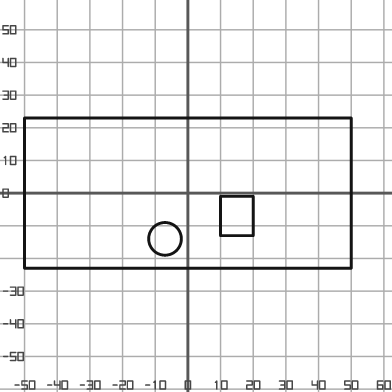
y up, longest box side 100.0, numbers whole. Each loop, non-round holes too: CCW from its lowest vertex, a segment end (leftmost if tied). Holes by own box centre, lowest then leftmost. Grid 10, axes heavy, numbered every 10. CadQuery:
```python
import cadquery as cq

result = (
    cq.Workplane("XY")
    .moveTo(-50.0, -23.0)
    .lineTo(50.0, -23.0)
    .lineTo(50.0, 23.0)
    .lineTo(-50.0, 23.0)
    .close()
    .moveTo(-7.0, -14.0)
    .circle(5.0)
    .moveTo(10.0, -13.0)
    .lineTo(20.0, -13.0)
    .lineTo(20.0, -1.0)
    .lineTo(10.0, -1.0)
    .close()
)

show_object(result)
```